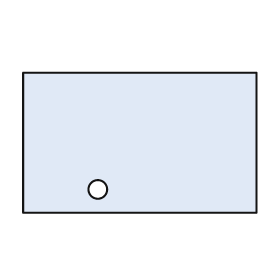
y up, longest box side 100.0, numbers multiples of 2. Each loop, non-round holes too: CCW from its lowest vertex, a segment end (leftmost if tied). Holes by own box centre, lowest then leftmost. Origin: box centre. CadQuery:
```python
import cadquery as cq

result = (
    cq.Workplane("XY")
    .moveTo(-50.0, -30.0)
    .lineTo(50.0, -30.0)
    .lineTo(50.0, 30.0)
    .lineTo(-50.0, 30.0)
    .close()
    .moveTo(-18.0, -20.0)
    .circle(4.0)
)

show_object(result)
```